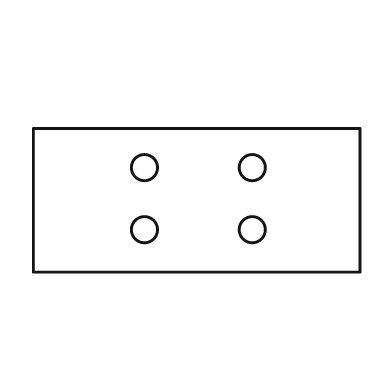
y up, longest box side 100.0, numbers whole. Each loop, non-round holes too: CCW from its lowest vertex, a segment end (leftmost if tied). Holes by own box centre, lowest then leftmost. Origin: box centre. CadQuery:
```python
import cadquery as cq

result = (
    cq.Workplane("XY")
    .moveTo(-50.0, -22.0)
    .lineTo(50.0, -22.0)
    .lineTo(50.0, 22.0)
    .lineTo(-50.0, 22.0)
    .close()
    .moveTo(-16.0, -9.0)
    .circle(4.0)
    .moveTo(17.0, -9.0)
    .circle(4.0)
    .moveTo(-16.0, 10.0)
    .circle(4.0)
    .moveTo(17.0, 10.0)
    .circle(4.0)
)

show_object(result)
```